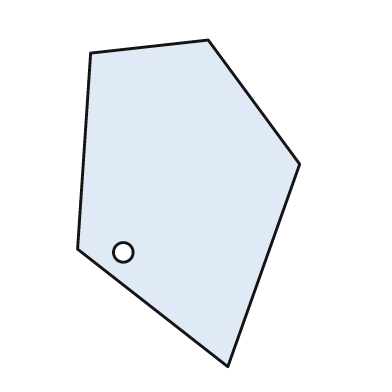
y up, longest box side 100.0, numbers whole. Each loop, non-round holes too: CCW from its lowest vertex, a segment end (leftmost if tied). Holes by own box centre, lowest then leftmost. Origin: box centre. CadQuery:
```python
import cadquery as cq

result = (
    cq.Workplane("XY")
    .moveTo(12.0, -50.0)
    .lineTo(34.0, 12.0)
    .lineTo(6.0, 50.0)
    .lineTo(-30.0, 46.0)
    .lineTo(-34.0, -14.0)
    .close()
    .moveTo(-20.0, -15.0)
    .circle(3.0)
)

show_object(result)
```